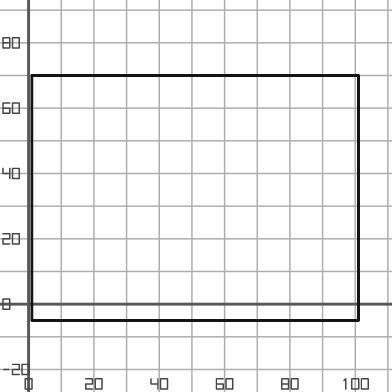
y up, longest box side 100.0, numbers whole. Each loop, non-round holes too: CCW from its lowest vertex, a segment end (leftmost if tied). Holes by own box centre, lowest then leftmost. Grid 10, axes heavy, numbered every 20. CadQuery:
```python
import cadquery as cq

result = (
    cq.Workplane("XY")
    .moveTo(1.0, -5.0)
    .lineTo(101.0, -5.0)
    .lineTo(101.0, 70.0)
    .lineTo(1.0, 70.0)
    .close()
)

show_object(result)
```